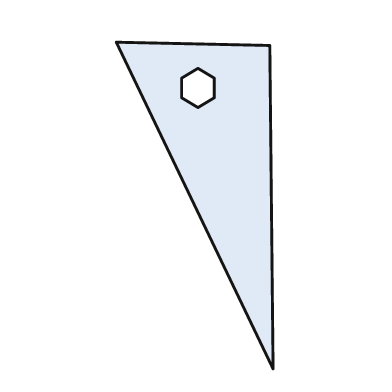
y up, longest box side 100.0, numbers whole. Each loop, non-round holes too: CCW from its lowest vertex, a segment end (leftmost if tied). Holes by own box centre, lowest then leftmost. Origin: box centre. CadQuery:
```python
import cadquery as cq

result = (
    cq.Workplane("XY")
    .moveTo(24.0, -50.0)
    .lineTo(23.0, 49.0)
    .lineTo(-24.0, 50.0)
    .close()
    .moveTo(1.0, 30.0)
    .lineTo(6.0, 33.0)
    .lineTo(6.0, 39.0)
    .lineTo(1.0, 42.0)
    .lineTo(-4.0, 39.0)
    .lineTo(-4.0, 33.0)
    .close()
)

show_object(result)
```